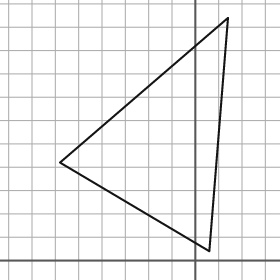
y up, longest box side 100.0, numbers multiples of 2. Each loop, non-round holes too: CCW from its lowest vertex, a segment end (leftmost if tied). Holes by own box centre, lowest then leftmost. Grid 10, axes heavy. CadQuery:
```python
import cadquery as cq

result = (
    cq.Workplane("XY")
    .moveTo(6.0, 4.0)
    .lineTo(14.0, 104.0)
    .lineTo(-58.0, 42.0)
    .close()
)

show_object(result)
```